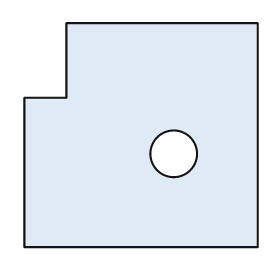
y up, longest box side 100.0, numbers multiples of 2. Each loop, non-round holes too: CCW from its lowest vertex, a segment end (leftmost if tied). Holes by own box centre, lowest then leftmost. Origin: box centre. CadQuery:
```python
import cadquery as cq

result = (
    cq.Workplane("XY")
    .moveTo(-50.0, -48.0)
    .lineTo(50.0, -48.0)
    .lineTo(50.0, 48.0)
    .lineTo(-32.0, 48.0)
    .lineTo(-32.0, 16.0)
    .lineTo(-50.0, 16.0)
    .close()
    .moveTo(14.0, -8.0)
    .circle(10.0)
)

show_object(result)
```